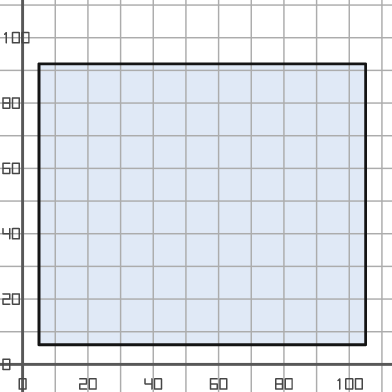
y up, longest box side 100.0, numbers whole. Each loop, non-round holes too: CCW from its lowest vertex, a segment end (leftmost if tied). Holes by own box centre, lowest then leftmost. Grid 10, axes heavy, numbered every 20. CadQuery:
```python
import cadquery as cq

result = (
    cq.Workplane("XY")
    .moveTo(5.0, 6.0)
    .lineTo(105.0, 6.0)
    .lineTo(105.0, 92.0)
    .lineTo(5.0, 92.0)
    .close()
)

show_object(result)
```